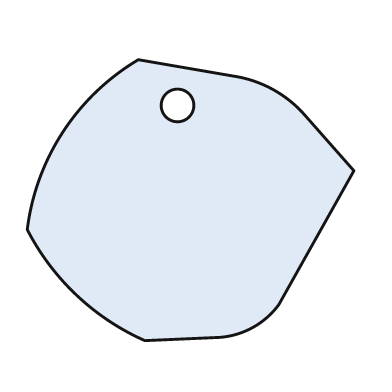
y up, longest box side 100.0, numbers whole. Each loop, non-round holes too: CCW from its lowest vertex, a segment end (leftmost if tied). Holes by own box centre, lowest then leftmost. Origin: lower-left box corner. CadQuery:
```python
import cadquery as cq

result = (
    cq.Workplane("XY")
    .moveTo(36.0, 0.0)
    .lineTo(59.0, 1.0)
    .threePointArc((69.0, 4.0), (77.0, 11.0))
    .lineTo(100.0, 52.0)
    .lineTo(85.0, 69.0)
    .threePointArc((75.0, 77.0), (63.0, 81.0))
    .lineTo(34.0, 86.0)
    .threePointArc((11.0, 64.0), (0.0, 34.0))
    .threePointArc((15.0, 14.0), (36.0, 0.0))
    .close()
    .moveTo(46.0, 72.0)
    .circle(5.0)
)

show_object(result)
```